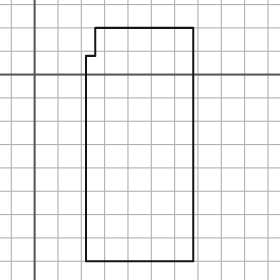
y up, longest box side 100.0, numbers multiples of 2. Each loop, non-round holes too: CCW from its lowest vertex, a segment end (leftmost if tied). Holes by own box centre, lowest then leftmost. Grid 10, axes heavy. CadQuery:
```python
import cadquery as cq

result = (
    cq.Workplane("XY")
    .moveTo(22.0, -80.0)
    .lineTo(68.0, -80.0)
    .lineTo(68.0, 20.0)
    .lineTo(26.0, 20.0)
    .lineTo(26.0, 8.0)
    .lineTo(22.0, 8.0)
    .close()
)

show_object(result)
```